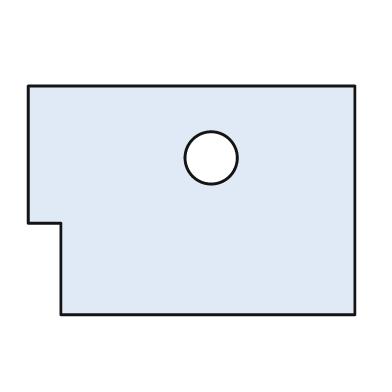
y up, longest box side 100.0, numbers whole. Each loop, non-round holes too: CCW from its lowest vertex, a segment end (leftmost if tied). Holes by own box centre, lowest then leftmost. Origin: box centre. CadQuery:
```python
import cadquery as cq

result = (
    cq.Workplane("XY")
    .moveTo(-40.0, -35.0)
    .lineTo(50.0, -35.0)
    .lineTo(50.0, 35.0)
    .lineTo(-50.0, 35.0)
    .lineTo(-50.0, -7.0)
    .lineTo(-40.0, -7.0)
    .close()
    .moveTo(6.0, 13.0)
    .circle(8.0)
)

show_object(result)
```